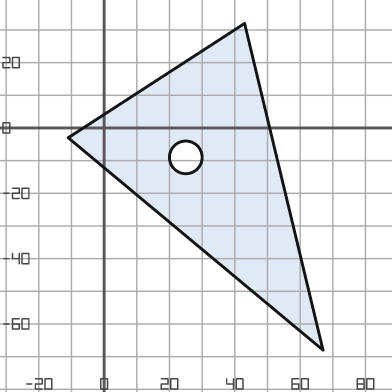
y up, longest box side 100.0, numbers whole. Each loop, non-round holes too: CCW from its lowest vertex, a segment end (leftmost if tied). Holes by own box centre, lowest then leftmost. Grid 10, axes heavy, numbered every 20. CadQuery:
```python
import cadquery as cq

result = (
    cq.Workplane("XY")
    .moveTo(67.0, -68.0)
    .lineTo(43.0, 32.0)
    .lineTo(-11.0, -3.0)
    .close()
    .moveTo(25.0, -9.0)
    .circle(5.0)
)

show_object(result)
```